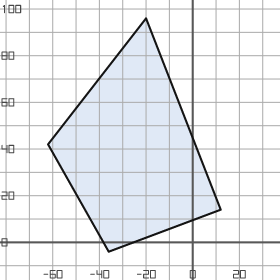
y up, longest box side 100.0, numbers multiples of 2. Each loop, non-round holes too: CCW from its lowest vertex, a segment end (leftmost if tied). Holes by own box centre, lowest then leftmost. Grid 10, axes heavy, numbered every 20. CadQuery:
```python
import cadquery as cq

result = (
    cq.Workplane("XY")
    .moveTo(-36.0, -4.0)
    .lineTo(12.0, 14.0)
    .lineTo(-20.0, 96.0)
    .lineTo(-62.0, 42.0)
    .close()
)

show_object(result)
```